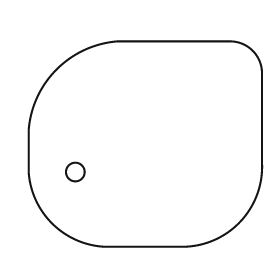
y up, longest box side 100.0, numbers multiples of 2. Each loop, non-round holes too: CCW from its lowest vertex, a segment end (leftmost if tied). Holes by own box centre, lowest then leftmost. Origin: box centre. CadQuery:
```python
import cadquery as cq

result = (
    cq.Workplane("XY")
    .moveTo(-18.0, -44.0)
    .lineTo(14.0, -44.0)
    .threePointArc((40.0, -34.0), (50.0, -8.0))
    .lineTo(50.0, 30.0)
    .threePointArc((46.0, 40.0), (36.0, 44.0))
    .lineTo(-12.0, 44.0)
    .threePointArc((-38.0, 32.0), (-50.0, 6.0))
    .lineTo(-50.0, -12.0)
    .threePointArc((-40.0, -34.0), (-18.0, -44.0))
    .close()
    .moveTo(-30.0, -12.0)
    .circle(4.0)
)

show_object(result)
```